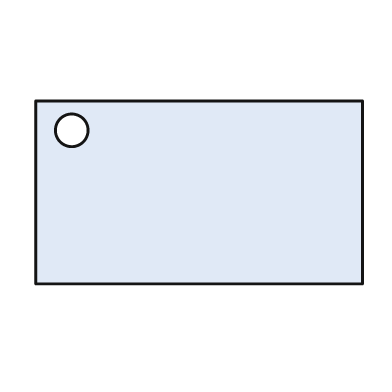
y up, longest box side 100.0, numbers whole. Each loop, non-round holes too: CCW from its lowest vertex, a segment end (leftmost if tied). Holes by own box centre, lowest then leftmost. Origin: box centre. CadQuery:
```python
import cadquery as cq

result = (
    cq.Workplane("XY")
    .moveTo(-50.0, -28.0)
    .lineTo(50.0, -28.0)
    .lineTo(50.0, 28.0)
    .lineTo(-50.0, 28.0)
    .close()
    .moveTo(-39.0, 19.0)
    .circle(5.0)
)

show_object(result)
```